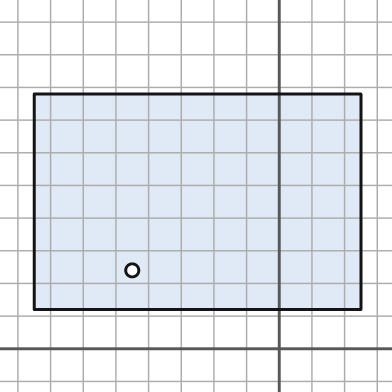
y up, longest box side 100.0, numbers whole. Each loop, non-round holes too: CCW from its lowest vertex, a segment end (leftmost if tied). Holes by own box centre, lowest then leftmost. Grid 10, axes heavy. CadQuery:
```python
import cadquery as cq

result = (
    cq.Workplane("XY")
    .moveTo(-75.0, 12.0)
    .lineTo(25.0, 12.0)
    .lineTo(25.0, 78.0)
    .lineTo(-75.0, 78.0)
    .close()
    .moveTo(-45.0, 24.0)
    .circle(2.0)
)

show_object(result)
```